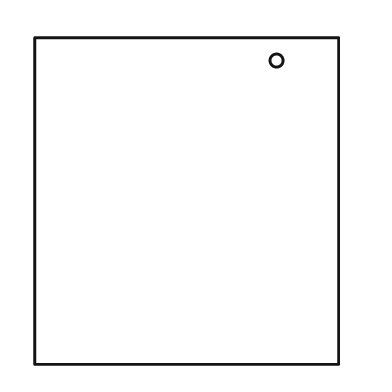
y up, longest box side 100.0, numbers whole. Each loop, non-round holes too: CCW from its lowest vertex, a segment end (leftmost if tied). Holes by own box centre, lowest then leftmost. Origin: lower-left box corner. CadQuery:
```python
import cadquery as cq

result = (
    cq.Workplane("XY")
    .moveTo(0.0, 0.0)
    .lineTo(93.0, 0.0)
    .lineTo(93.0, 100.0)
    .lineTo(0.0, 100.0)
    .close()
    .moveTo(74.0, 93.0)
    .circle(2.0)
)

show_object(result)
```